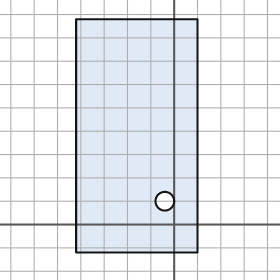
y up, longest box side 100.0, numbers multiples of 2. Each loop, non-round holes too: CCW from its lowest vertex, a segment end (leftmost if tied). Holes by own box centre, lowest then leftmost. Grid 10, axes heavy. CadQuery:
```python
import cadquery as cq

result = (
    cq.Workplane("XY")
    .moveTo(-42.0, -12.0)
    .lineTo(10.0, -12.0)
    .lineTo(10.0, 88.0)
    .lineTo(-42.0, 88.0)
    .close()
    .moveTo(-4.0, 10.0)
    .circle(4.0)
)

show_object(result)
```